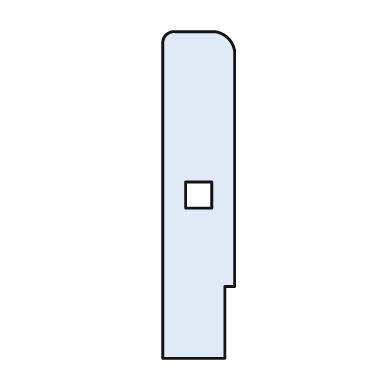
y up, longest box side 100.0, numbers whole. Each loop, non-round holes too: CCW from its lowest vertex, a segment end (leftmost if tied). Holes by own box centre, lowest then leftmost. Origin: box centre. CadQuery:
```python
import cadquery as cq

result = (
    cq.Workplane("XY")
    .moveTo(-11.0, -50.0)
    .lineTo(8.0, -50.0)
    .lineTo(8.0, -28.0)
    .lineTo(11.0, -28.0)
    .lineTo(11.0, 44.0)
    .threePointArc((9.0, 48.0), (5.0, 50.0))
    .lineTo(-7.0, 50.0)
    .threePointArc((-10.0, 49.0), (-11.0, 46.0))
    .close()
    .moveTo(-4.0, -4.0)
    .lineTo(4.0, -4.0)
    .lineTo(4.0, 4.0)
    .lineTo(-4.0, 4.0)
    .close()
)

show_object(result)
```